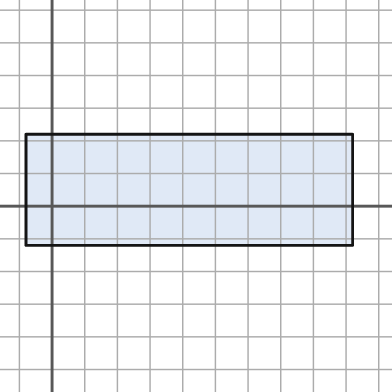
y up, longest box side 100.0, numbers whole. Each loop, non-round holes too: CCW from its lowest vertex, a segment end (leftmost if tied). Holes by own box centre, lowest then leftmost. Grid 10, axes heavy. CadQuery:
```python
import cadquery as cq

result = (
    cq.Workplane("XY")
    .moveTo(-8.0, -12.0)
    .lineTo(92.0, -12.0)
    .lineTo(92.0, 22.0)
    .lineTo(-8.0, 22.0)
    .close()
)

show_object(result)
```